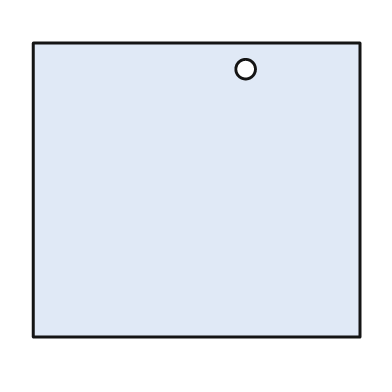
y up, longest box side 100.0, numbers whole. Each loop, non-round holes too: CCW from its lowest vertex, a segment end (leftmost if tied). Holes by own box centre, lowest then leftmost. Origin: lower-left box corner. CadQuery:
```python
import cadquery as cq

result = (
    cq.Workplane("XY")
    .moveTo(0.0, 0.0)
    .lineTo(100.0, 0.0)
    .lineTo(100.0, 90.0)
    .lineTo(0.0, 90.0)
    .close()
    .moveTo(65.0, 82.0)
    .circle(3.0)
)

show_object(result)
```